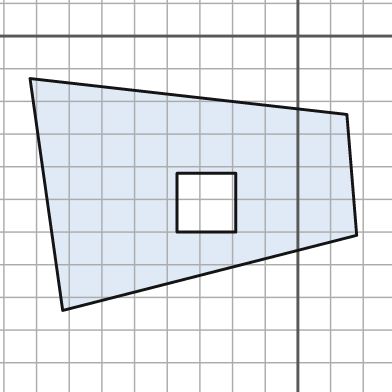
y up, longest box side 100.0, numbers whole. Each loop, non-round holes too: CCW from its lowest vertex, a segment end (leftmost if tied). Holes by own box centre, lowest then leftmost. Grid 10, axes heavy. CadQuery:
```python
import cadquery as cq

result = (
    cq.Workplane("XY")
    .moveTo(-72.0, -84.0)
    .lineTo(18.0, -61.0)
    .lineTo(15.0, -24.0)
    .lineTo(-82.0, -13.0)
    .close()
    .moveTo(-37.0, -60.0)
    .lineTo(-19.0, -60.0)
    .lineTo(-19.0, -42.0)
    .lineTo(-37.0, -42.0)
    .close()
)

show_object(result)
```